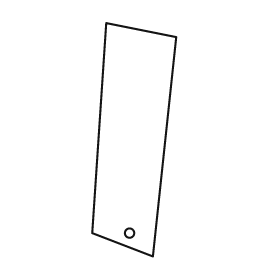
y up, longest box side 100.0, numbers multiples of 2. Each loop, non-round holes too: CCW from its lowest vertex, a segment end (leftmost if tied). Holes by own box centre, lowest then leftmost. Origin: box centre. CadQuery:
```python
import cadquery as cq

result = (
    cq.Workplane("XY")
    .moveTo(8.0, -50.0)
    .lineTo(18.0, 44.0)
    .lineTo(-12.0, 50.0)
    .lineTo(-18.0, -40.0)
    .close()
    .moveTo(-2.0, -40.0)
    .circle(2.0)
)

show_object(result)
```